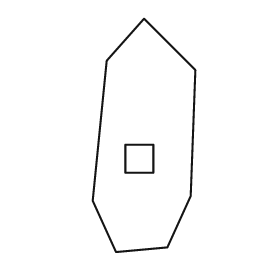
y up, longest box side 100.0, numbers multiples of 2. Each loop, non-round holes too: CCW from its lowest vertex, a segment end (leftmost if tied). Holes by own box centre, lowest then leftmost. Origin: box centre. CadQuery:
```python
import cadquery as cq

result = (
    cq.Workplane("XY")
    .moveTo(-12.0, -50.0)
    .lineTo(10.0, -48.0)
    .lineTo(20.0, -26.0)
    .lineTo(22.0, 28.0)
    .lineTo(0.0, 50.0)
    .lineTo(-16.0, 32.0)
    .lineTo(-22.0, -28.0)
    .close()
    .moveTo(-8.0, -16.0)
    .lineTo(4.0, -16.0)
    .lineTo(4.0, -4.0)
    .lineTo(-8.0, -4.0)
    .close()
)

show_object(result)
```